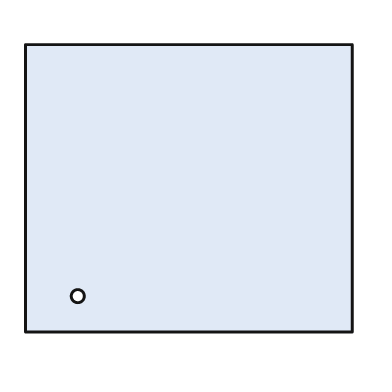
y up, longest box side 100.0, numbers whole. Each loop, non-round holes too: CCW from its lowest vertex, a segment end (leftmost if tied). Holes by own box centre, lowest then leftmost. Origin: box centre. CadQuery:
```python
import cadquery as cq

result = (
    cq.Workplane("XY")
    .moveTo(-50.0, -44.0)
    .lineTo(50.0, -44.0)
    .lineTo(50.0, 44.0)
    .lineTo(-50.0, 44.0)
    .close()
    .moveTo(-34.0, -33.0)
    .circle(2.0)
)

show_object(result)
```